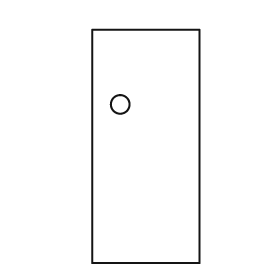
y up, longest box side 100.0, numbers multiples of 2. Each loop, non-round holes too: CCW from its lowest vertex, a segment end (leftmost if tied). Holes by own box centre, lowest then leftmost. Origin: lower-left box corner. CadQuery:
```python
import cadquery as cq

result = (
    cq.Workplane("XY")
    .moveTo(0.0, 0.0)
    .lineTo(46.0, 0.0)
    .lineTo(46.0, 100.0)
    .lineTo(0.0, 100.0)
    .close()
    .moveTo(12.0, 68.0)
    .circle(4.0)
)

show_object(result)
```